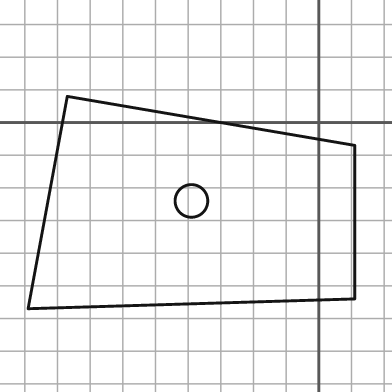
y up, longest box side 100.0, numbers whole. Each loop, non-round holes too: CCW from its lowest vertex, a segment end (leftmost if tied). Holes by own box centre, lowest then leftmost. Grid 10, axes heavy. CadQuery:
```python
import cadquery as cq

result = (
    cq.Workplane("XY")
    .moveTo(-89.0, -57.0)
    .lineTo(11.0, -54.0)
    .lineTo(11.0, -7.0)
    .lineTo(-77.0, 8.0)
    .close()
    .moveTo(-39.0, -24.0)
    .circle(5.0)
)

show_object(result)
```